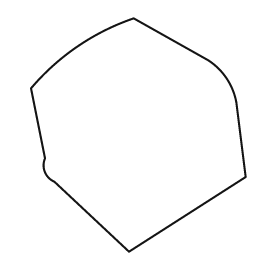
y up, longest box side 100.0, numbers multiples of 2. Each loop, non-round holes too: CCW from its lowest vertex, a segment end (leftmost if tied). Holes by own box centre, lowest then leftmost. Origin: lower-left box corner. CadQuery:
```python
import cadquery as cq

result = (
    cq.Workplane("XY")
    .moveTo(42.0, 0.0)
    .lineTo(92.0, 32.0)
    .lineTo(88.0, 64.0)
    .threePointArc((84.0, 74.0), (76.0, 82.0))
    .lineTo(44.0, 100.0)
    .threePointArc((20.0, 88.0), (0.0, 70.0))
    .lineTo(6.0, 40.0)
    .threePointArc((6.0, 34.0), (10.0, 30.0))
    .close()
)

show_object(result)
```